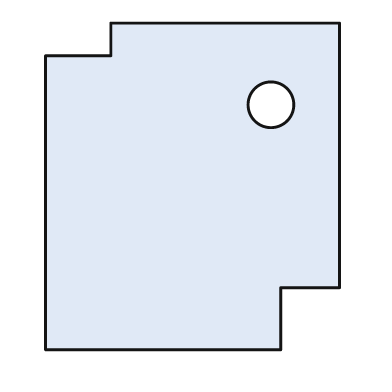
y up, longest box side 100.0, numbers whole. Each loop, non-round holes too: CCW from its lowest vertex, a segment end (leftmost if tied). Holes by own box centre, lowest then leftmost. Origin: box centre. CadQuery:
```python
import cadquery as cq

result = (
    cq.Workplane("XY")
    .moveTo(-45.0, -50.0)
    .lineTo(27.0, -50.0)
    .lineTo(27.0, -31.0)
    .lineTo(45.0, -31.0)
    .lineTo(45.0, 50.0)
    .lineTo(-25.0, 50.0)
    .lineTo(-25.0, 40.0)
    .lineTo(-45.0, 40.0)
    .close()
    .moveTo(24.0, 25.0)
    .circle(7.0)
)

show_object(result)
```